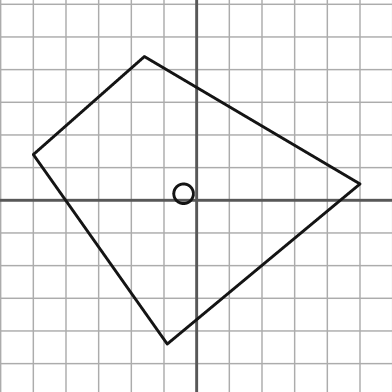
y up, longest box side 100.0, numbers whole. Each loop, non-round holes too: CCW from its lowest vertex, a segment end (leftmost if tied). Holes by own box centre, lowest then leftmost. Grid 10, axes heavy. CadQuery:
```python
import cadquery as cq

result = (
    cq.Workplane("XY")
    .moveTo(-9.0, -44.0)
    .lineTo(50.0, 5.0)
    .lineTo(-16.0, 44.0)
    .lineTo(-50.0, 14.0)
    .close()
    .moveTo(-4.0, 2.0)
    .circle(3.0)
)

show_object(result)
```